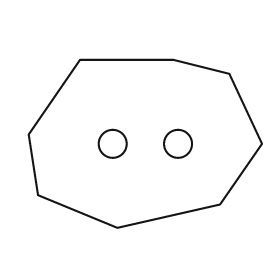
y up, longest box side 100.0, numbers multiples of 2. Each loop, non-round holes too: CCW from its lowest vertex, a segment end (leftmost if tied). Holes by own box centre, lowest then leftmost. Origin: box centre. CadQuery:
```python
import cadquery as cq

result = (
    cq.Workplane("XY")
    .moveTo(-12.0, -36.0)
    .lineTo(32.0, -26.0)
    .lineTo(50.0, 0.0)
    .lineTo(36.0, 30.0)
    .lineTo(12.0, 36.0)
    .lineTo(-28.0, 36.0)
    .lineTo(-50.0, 4.0)
    .lineTo(-46.0, -22.0)
    .close()
    .moveTo(-14.0, 0.0)
    .circle(6.0)
    .moveTo(14.0, 0.0)
    .circle(6.0)
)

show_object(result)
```